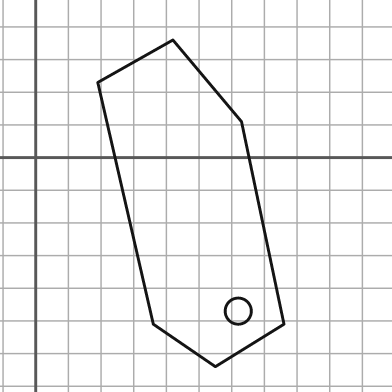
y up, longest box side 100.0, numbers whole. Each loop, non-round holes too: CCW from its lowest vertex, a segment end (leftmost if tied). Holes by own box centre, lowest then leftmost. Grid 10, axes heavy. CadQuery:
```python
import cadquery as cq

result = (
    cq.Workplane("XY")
    .moveTo(55.0, -64.0)
    .lineTo(76.0, -51.0)
    .lineTo(63.0, 11.0)
    .lineTo(42.0, 36.0)
    .lineTo(19.0, 23.0)
    .lineTo(36.0, -51.0)
    .close()
    .moveTo(62.0, -47.0)
    .circle(4.0)
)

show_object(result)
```